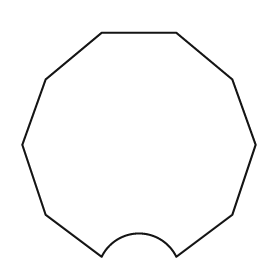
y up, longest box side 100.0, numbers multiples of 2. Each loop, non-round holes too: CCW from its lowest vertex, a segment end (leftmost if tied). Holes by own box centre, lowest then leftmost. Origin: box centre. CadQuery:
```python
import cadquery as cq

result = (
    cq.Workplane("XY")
    .moveTo(-16.0, -48.0)
    .threePointArc((0.0, -38.0), (16.0, -48.0))
    .lineTo(40.0, -30.0)
    .lineTo(50.0, 0.0)
    .lineTo(40.0, 28.0)
    .lineTo(16.0, 48.0)
    .lineTo(-16.0, 48.0)
    .lineTo(-40.0, 28.0)
    .lineTo(-50.0, 0.0)
    .lineTo(-40.0, -30.0)
    .close()
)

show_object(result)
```